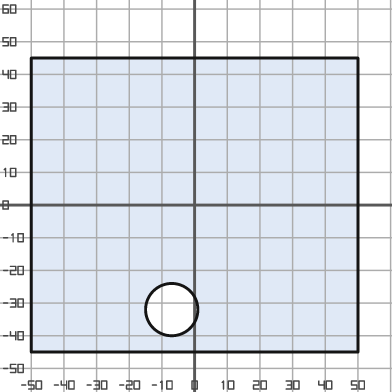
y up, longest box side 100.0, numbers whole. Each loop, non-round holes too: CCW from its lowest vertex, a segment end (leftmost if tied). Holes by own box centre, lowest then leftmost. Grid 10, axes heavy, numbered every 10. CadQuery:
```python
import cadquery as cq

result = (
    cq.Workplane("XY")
    .moveTo(-50.0, -45.0)
    .lineTo(50.0, -45.0)
    .lineTo(50.0, 45.0)
    .lineTo(-50.0, 45.0)
    .close()
    .moveTo(-7.0, -32.0)
    .circle(8.0)
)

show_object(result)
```